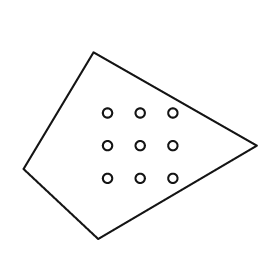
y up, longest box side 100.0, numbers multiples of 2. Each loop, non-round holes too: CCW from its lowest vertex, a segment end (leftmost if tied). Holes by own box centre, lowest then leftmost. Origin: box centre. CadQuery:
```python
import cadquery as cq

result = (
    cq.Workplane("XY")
    .moveTo(-18.0, -40.0)
    .lineTo(50.0, 0.0)
    .lineTo(-20.0, 40.0)
    .lineTo(-50.0, -10.0)
    .close()
    .moveTo(-14.0, -14.0)
    .circle(2.0)
    .moveTo(0.0, -14.0)
    .circle(2.0)
    .moveTo(14.0, -14.0)
    .circle(2.0)
    .moveTo(-14.0, 0.0)
    .circle(2.0)
    .moveTo(0.0, 0.0)
    .circle(2.0)
    .moveTo(14.0, 0.0)
    .circle(2.0)
    .moveTo(-14.0, 14.0)
    .circle(2.0)
    .moveTo(0.0, 14.0)
    .circle(2.0)
    .moveTo(14.0, 14.0)
    .circle(2.0)
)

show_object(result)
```